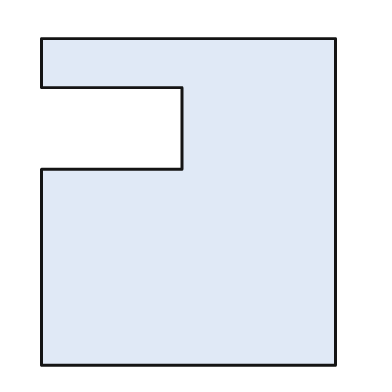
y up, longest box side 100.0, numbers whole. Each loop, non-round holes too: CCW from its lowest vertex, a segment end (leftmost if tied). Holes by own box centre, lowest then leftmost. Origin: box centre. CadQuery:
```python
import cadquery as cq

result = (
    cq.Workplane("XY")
    .moveTo(-45.0, -50.0)
    .lineTo(45.0, -50.0)
    .lineTo(45.0, 50.0)
    .lineTo(-45.0, 50.0)
    .lineTo(-45.0, 35.0)
    .lineTo(-2.0, 35.0)
    .lineTo(-2.0, 10.0)
    .lineTo(-45.0, 10.0)
    .close()
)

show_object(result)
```